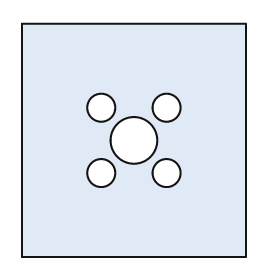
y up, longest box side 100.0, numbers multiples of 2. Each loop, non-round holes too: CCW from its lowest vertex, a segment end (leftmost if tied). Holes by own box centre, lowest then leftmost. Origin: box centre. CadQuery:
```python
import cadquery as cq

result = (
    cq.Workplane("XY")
    .moveTo(-48.0, -50.0)
    .lineTo(48.0, -50.0)
    .lineTo(48.0, 50.0)
    .lineTo(-48.0, 50.0)
    .close()
    .moveTo(-14.0, -14.0)
    .circle(6.0)
    .moveTo(14.0, -14.0)
    .circle(6.0)
    .moveTo(0.0, 0.0)
    .circle(10.0)
    .moveTo(-14.0, 14.0)
    .circle(6.0)
    .moveTo(14.0, 14.0)
    .circle(6.0)
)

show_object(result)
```